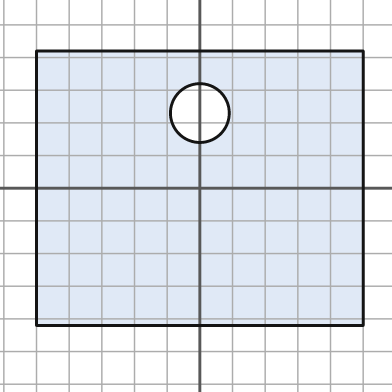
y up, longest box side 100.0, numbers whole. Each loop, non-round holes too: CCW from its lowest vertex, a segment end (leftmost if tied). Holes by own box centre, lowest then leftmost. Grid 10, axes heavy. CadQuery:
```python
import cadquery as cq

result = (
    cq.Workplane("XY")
    .moveTo(-50.0, -42.0)
    .lineTo(50.0, -42.0)
    .lineTo(50.0, 42.0)
    .lineTo(-50.0, 42.0)
    .close()
    .moveTo(0.0, 23.0)
    .circle(9.0)
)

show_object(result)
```